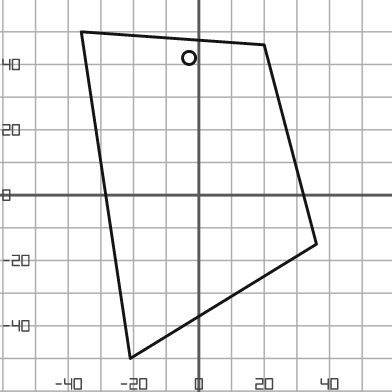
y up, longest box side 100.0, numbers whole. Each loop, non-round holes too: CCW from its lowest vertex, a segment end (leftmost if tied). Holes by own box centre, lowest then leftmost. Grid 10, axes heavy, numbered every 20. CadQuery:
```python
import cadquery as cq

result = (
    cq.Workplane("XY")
    .moveTo(-21.0, -50.0)
    .lineTo(36.0, -15.0)
    .lineTo(20.0, 46.0)
    .lineTo(-36.0, 50.0)
    .close()
    .moveTo(-3.0, 42.0)
    .circle(2.0)
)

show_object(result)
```